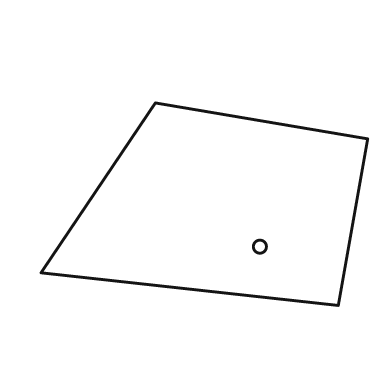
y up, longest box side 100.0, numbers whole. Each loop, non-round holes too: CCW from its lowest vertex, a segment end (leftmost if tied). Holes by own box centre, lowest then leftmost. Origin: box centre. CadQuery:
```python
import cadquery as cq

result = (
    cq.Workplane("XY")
    .moveTo(41.0, -31.0)
    .lineTo(50.0, 20.0)
    .lineTo(-15.0, 31.0)
    .lineTo(-50.0, -21.0)
    .close()
    .moveTo(17.0, -13.0)
    .circle(2.0)
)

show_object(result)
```